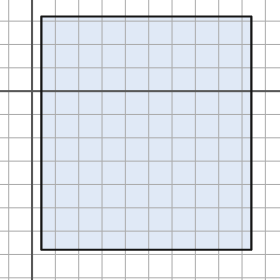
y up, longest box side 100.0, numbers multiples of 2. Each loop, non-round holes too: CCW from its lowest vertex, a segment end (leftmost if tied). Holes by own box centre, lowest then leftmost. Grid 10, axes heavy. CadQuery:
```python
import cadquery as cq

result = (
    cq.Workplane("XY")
    .moveTo(4.0, -68.0)
    .lineTo(94.0, -68.0)
    .lineTo(94.0, 32.0)
    .lineTo(4.0, 32.0)
    .close()
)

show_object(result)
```